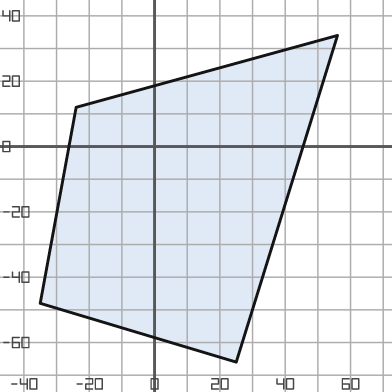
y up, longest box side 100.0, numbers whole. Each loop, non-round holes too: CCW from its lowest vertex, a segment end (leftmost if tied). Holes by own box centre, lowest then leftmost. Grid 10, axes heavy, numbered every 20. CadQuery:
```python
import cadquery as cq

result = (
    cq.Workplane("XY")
    .moveTo(25.0, -66.0)
    .lineTo(56.0, 34.0)
    .lineTo(-24.0, 12.0)
    .lineTo(-35.0, -48.0)
    .close()
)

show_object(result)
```